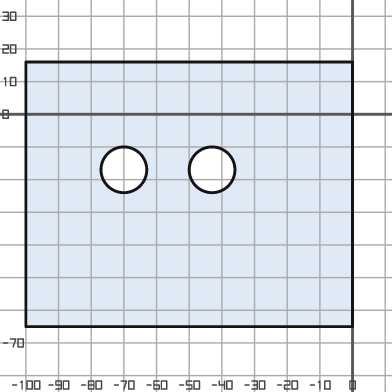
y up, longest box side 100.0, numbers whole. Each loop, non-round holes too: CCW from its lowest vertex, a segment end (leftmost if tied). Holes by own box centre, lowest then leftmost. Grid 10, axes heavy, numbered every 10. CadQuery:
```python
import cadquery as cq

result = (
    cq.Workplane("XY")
    .moveTo(-100.0, -65.0)
    .lineTo(0.0, -65.0)
    .lineTo(0.0, 16.0)
    .lineTo(-100.0, 16.0)
    .close()
    .moveTo(-70.0, -17.0)
    .circle(7.0)
    .moveTo(-43.0, -17.0)
    .circle(7.0)
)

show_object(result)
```